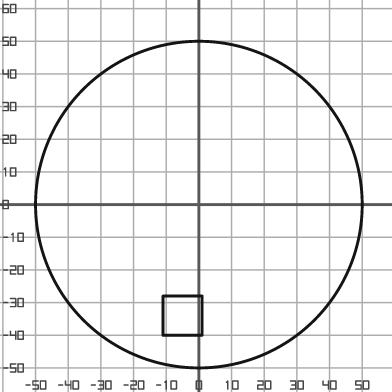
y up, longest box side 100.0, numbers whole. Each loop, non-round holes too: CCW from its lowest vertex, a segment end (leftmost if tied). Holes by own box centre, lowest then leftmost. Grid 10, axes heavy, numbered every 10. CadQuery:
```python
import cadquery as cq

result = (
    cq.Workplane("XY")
    .moveTo(0.0, 0.0)
    .circle(50.0)
    .moveTo(-11.0, -40.0)
    .lineTo(1.0, -40.0)
    .lineTo(1.0, -28.0)
    .lineTo(-11.0, -28.0)
    .close()
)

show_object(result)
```